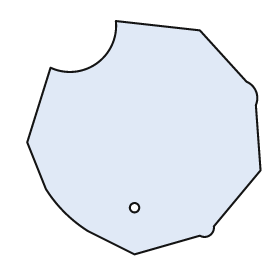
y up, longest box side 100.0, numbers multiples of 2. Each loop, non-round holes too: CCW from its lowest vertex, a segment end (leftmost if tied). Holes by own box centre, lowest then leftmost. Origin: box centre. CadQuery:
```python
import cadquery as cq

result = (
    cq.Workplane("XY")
    .moveTo(-4.0, -50.0)
    .lineTo(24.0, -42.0)
    .threePointArc((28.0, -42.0), (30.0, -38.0))
    .lineTo(50.0, -14.0)
    .lineTo(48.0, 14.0)
    .threePointArc((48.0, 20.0), (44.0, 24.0))
    .lineTo(24.0, 46.0)
    .lineTo(-12.0, 50.0)
    .threePointArc((-20.0, 32.0), (-40.0, 30.0))
    .lineTo(-50.0, -2.0)
    .lineTo(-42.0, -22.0)
    .threePointArc((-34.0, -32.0), (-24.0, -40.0))
    .close()
    .moveTo(-4.0, -30.0)
    .circle(2.0)
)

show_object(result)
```